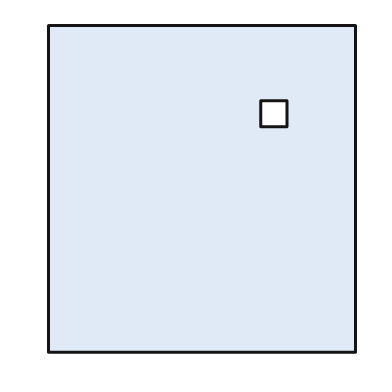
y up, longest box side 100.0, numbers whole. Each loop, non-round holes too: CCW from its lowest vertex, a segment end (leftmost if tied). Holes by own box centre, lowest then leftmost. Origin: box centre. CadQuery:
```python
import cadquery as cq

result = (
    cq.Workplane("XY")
    .moveTo(-47.0, -50.0)
    .lineTo(47.0, -50.0)
    .lineTo(47.0, 50.0)
    .lineTo(-47.0, 50.0)
    .close()
    .moveTo(18.0, 19.0)
    .lineTo(26.0, 19.0)
    .lineTo(26.0, 27.0)
    .lineTo(18.0, 27.0)
    .close()
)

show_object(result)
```